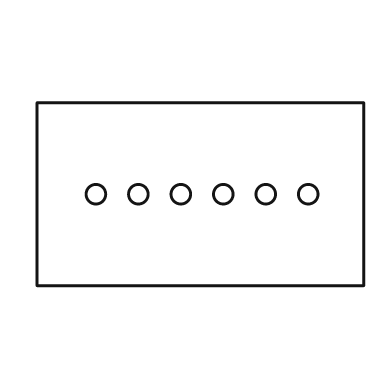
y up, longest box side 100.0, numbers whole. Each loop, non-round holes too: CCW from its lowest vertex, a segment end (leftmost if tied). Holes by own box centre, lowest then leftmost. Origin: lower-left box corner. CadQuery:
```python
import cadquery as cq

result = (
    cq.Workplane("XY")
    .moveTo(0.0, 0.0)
    .lineTo(100.0, 0.0)
    .lineTo(100.0, 56.0)
    .lineTo(0.0, 56.0)
    .close()
    .moveTo(18.0, 28.0)
    .circle(3.0)
    .moveTo(31.0, 28.0)
    .circle(3.0)
    .moveTo(44.0, 28.0)
    .circle(3.0)
    .moveTo(57.0, 28.0)
    .circle(3.0)
    .moveTo(70.0, 28.0)
    .circle(3.0)
    .moveTo(83.0, 28.0)
    .circle(3.0)
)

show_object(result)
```